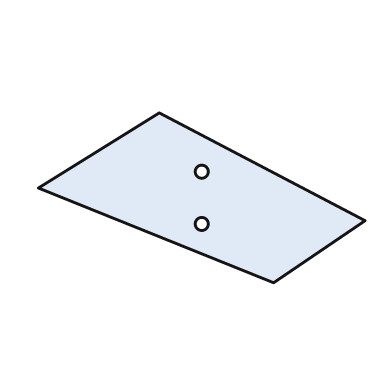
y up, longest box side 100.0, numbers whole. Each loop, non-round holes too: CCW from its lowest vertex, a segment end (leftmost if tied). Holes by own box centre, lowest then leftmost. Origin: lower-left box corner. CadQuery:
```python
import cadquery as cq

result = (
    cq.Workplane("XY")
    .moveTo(72.0, 0.0)
    .lineTo(100.0, 19.0)
    .lineTo(37.0, 52.0)
    .lineTo(0.0, 29.0)
    .close()
    .moveTo(50.0, 18.0)
    .circle(2.0)
    .moveTo(50.0, 34.0)
    .circle(2.0)
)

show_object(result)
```